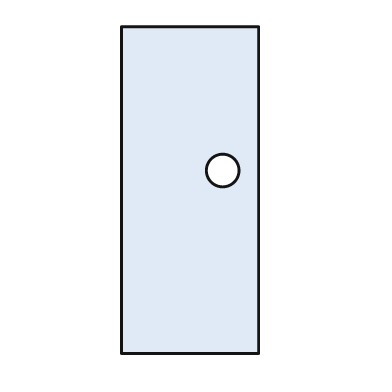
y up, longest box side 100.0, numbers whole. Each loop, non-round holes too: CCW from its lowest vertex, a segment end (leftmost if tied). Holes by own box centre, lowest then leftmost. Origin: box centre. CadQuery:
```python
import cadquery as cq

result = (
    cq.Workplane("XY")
    .moveTo(-21.0, -50.0)
    .lineTo(21.0, -50.0)
    .lineTo(21.0, 50.0)
    .lineTo(-21.0, 50.0)
    .close()
    .moveTo(10.0, 6.0)
    .circle(5.0)
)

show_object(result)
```